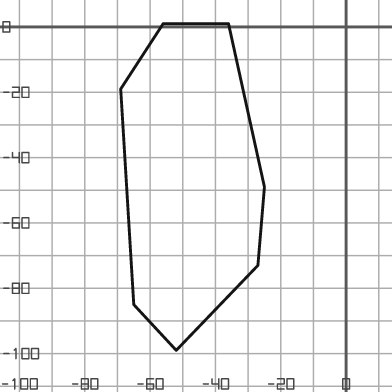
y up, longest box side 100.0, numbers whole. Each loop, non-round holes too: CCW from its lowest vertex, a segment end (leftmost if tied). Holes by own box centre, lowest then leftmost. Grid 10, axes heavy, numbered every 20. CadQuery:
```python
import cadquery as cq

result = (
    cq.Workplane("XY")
    .moveTo(-52.0, -99.0)
    .lineTo(-27.0, -73.0)
    .lineTo(-25.0, -49.0)
    .lineTo(-36.0, 1.0)
    .lineTo(-56.0, 1.0)
    .lineTo(-69.0, -19.0)
    .lineTo(-65.0, -85.0)
    .close()
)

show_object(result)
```